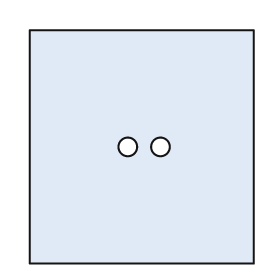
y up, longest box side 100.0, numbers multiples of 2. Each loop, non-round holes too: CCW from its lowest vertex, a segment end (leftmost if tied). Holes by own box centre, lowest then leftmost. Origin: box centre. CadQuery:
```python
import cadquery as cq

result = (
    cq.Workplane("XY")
    .moveTo(-48.0, -50.0)
    .lineTo(48.0, -50.0)
    .lineTo(48.0, 50.0)
    .lineTo(-48.0, 50.0)
    .close()
    .moveTo(-6.0, 0.0)
    .circle(4.0)
    .moveTo(8.0, 0.0)
    .circle(4.0)
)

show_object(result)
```